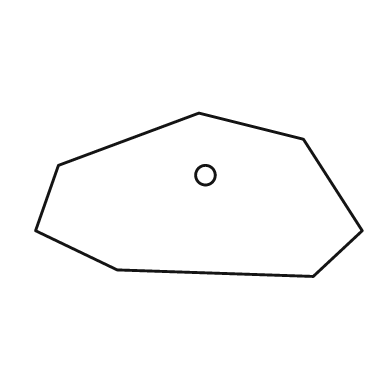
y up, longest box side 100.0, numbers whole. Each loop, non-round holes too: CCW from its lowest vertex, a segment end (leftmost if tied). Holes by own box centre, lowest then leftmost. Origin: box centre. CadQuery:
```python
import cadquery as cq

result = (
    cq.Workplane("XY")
    .moveTo(35.0, -25.0)
    .lineTo(50.0, -11.0)
    .lineTo(32.0, 17.0)
    .lineTo(0.0, 25.0)
    .lineTo(-43.0, 9.0)
    .lineTo(-50.0, -11.0)
    .lineTo(-25.0, -23.0)
    .close()
    .moveTo(2.0, 6.0)
    .circle(3.0)
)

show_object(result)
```